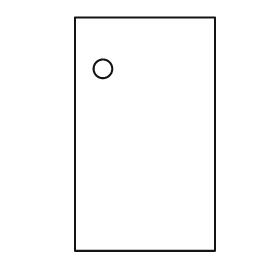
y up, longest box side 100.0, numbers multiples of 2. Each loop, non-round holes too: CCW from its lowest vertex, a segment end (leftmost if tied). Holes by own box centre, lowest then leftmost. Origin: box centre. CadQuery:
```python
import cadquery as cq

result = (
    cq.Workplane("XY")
    .moveTo(-30.0, -50.0)
    .lineTo(30.0, -50.0)
    .lineTo(30.0, 50.0)
    .lineTo(-30.0, 50.0)
    .close()
    .moveTo(-18.0, 28.0)
    .circle(4.0)
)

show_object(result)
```